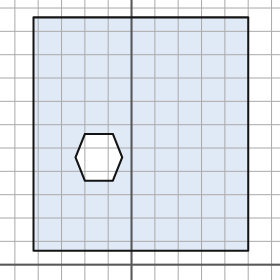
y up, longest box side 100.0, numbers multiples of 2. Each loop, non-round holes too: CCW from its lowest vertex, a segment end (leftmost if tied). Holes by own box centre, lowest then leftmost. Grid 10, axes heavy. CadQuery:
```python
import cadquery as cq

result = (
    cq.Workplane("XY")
    .moveTo(-42.0, 6.0)
    .lineTo(50.0, 6.0)
    .lineTo(50.0, 106.0)
    .lineTo(-42.0, 106.0)
    .close()
    .moveTo(-20.0, 36.0)
    .lineTo(-8.0, 36.0)
    .lineTo(-4.0, 46.0)
    .lineTo(-8.0, 56.0)
    .lineTo(-20.0, 56.0)
    .lineTo(-24.0, 46.0)
    .close()
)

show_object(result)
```